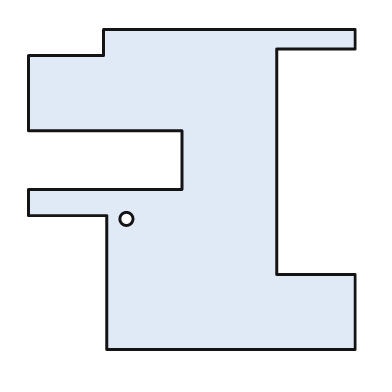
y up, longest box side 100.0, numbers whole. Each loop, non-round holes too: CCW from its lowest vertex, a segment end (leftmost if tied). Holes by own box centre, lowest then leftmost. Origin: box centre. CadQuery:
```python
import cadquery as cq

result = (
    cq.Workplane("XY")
    .moveTo(-26.0, -49.0)
    .lineTo(50.0, -49.0)
    .lineTo(50.0, -26.0)
    .lineTo(26.0, -26.0)
    .lineTo(26.0, 43.0)
    .lineTo(50.0, 43.0)
    .lineTo(50.0, 49.0)
    .lineTo(-27.0, 49.0)
    .lineTo(-27.0, 41.0)
    .lineTo(-50.0, 41.0)
    .lineTo(-50.0, 18.0)
    .lineTo(-3.0, 18.0)
    .lineTo(-3.0, 0.0)
    .lineTo(-50.0, 0.0)
    .lineTo(-50.0, -8.0)
    .lineTo(-26.0, -8.0)
    .close()
    .moveTo(-20.0, -9.0)
    .circle(2.0)
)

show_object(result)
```